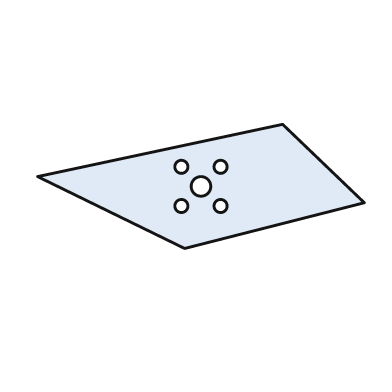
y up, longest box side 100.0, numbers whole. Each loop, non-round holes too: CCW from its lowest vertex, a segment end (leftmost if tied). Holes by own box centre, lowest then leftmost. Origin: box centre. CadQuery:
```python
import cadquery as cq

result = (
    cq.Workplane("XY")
    .moveTo(-5.0, -19.0)
    .lineTo(50.0, -5.0)
    .lineTo(25.0, 19.0)
    .lineTo(-50.0, 3.0)
    .close()
    .moveTo(-6.0, -6.0)
    .circle(2.0)
    .moveTo(6.0, -6.0)
    .circle(2.0)
    .moveTo(0.0, 0.0)
    .circle(3.0)
    .moveTo(-6.0, 6.0)
    .circle(2.0)
    .moveTo(6.0, 6.0)
    .circle(2.0)
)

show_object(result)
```